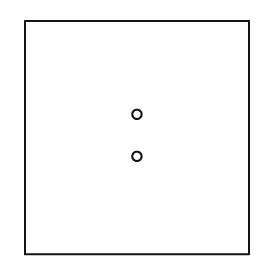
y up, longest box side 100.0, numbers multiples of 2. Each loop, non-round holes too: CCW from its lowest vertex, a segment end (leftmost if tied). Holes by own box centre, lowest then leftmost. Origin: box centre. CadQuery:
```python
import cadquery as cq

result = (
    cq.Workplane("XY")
    .moveTo(-48.0, -50.0)
    .lineTo(48.0, -50.0)
    .lineTo(48.0, 50.0)
    .lineTo(-48.0, 50.0)
    .close()
    .moveTo(0.0, -8.0)
    .circle(2.0)
    .moveTo(0.0, 10.0)
    .circle(2.0)
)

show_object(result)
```